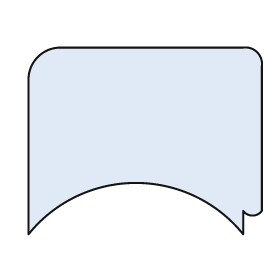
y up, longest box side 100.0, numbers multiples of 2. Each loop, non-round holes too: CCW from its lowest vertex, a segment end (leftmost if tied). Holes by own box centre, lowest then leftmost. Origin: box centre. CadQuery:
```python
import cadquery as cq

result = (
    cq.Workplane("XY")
    .moveTo(-50.0, -40.0)
    .threePointArc((-4.0, -18.0), (42.0, -40.0))
    .lineTo(42.0, -30.0)
    .threePointArc((46.0, -32.0), (50.0, -30.0))
    .lineTo(50.0, 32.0)
    .threePointArc((48.0, 38.0), (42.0, 40.0))
    .lineTo(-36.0, 40.0)
    .threePointArc((-46.0, 36.0), (-50.0, 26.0))
    .close()
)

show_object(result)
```